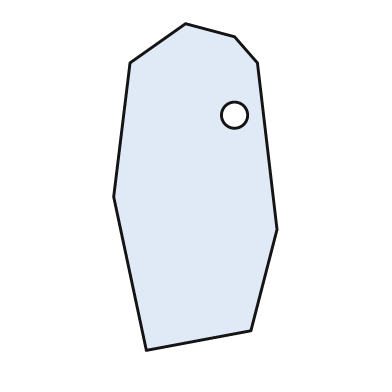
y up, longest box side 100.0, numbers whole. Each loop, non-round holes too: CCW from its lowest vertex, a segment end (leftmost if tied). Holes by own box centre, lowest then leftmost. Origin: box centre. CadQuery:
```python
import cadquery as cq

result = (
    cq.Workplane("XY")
    .moveTo(-15.0, -50.0)
    .lineTo(17.0, -44.0)
    .lineTo(25.0, -13.0)
    .lineTo(19.0, 38.0)
    .lineTo(12.0, 46.0)
    .lineTo(-3.0, 50.0)
    .lineTo(-20.0, 38.0)
    .lineTo(-25.0, -3.0)
    .close()
    .moveTo(12.0, 22.0)
    .circle(4.0)
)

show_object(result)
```